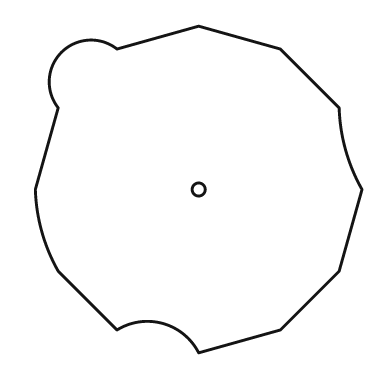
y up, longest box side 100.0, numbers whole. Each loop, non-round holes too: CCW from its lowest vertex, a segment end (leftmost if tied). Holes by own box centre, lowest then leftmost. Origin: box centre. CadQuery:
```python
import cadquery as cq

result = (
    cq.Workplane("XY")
    .moveTo(0.0, -50.0)
    .lineTo(25.0, -43.0)
    .lineTo(43.0, -25.0)
    .lineTo(50.0, 0.0)
    .threePointArc((45.0, 12.0), (43.0, 25.0))
    .lineTo(25.0, 43.0)
    .lineTo(0.0, 50.0)
    .lineTo(-25.0, 43.0)
    .threePointArc((-42.0, 42.0), (-43.0, 25.0))
    .lineTo(-50.0, 0.0)
    .threePointArc((-48.0, -13.0), (-43.0, -25.0))
    .lineTo(-25.0, -43.0)
    .threePointArc((-11.0, -41.0), (0.0, -50.0))
    .close()
    .moveTo(0.0, 0.0)
    .circle(2.0)
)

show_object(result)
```